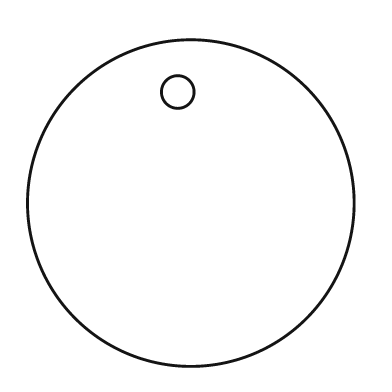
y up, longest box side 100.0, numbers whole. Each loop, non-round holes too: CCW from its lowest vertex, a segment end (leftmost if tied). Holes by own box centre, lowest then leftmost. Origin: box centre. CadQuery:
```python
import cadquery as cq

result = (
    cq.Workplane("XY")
    .moveTo(0.0, 0.0)
    .circle(50.0)
    .moveTo(-4.0, 34.0)
    .circle(5.0)
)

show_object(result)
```